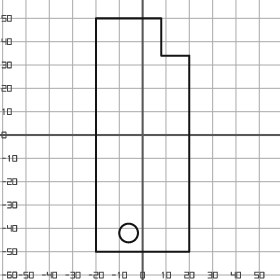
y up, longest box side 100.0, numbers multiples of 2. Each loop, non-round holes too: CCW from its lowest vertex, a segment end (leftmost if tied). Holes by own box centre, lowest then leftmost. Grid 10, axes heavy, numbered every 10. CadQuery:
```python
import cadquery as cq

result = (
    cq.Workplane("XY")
    .moveTo(-20.0, -50.0)
    .lineTo(20.0, -50.0)
    .lineTo(20.0, 34.0)
    .lineTo(8.0, 34.0)
    .lineTo(8.0, 50.0)
    .lineTo(-20.0, 50.0)
    .close()
    .moveTo(-6.0, -42.0)
    .circle(4.0)
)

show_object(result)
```